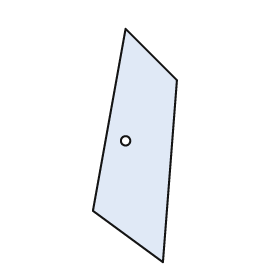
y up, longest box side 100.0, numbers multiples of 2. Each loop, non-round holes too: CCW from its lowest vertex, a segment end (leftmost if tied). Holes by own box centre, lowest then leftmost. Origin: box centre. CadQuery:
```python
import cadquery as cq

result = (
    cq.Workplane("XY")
    .moveTo(12.0, -50.0)
    .lineTo(18.0, 28.0)
    .lineTo(-4.0, 50.0)
    .lineTo(-18.0, -28.0)
    .close()
    .moveTo(-4.0, 2.0)
    .circle(2.0)
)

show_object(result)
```